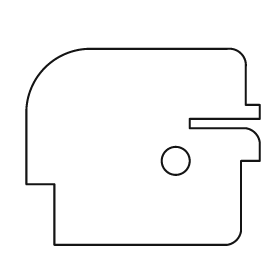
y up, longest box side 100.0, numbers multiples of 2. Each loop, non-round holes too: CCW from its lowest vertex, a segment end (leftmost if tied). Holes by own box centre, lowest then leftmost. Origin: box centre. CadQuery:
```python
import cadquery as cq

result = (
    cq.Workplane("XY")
    .moveTo(-38.0, -42.0)
    .lineTo(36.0, -42.0)
    .threePointArc((40.0, -40.0), (42.0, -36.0))
    .lineTo(42.0, -6.0)
    .lineTo(50.0, -6.0)
    .lineTo(50.0, 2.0)
    .threePointArc((48.0, 6.0), (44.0, 8.0))
    .lineTo(20.0, 8.0)
    .lineTo(20.0, 12.0)
    .lineTo(50.0, 12.0)
    .lineTo(50.0, 18.0)
    .lineTo(44.0, 18.0)
    .lineTo(44.0, 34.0)
    .threePointArc((42.0, 40.0), (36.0, 42.0))
    .lineTo(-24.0, 42.0)
    .threePointArc((-42.0, 34.0), (-50.0, 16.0))
    .lineTo(-50.0, -16.0)
    .lineTo(-38.0, -16.0)
    .close()
    .moveTo(14.0, -6.0)
    .circle(6.0)
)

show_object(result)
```